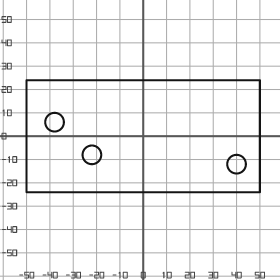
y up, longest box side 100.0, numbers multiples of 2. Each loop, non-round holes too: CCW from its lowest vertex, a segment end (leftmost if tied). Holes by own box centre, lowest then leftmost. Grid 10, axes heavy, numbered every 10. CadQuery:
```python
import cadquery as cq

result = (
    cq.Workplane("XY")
    .moveTo(-50.0, -24.0)
    .lineTo(50.0, -24.0)
    .lineTo(50.0, 24.0)
    .lineTo(-50.0, 24.0)
    .close()
    .moveTo(40.0, -12.0)
    .circle(4.0)
    .moveTo(-22.0, -8.0)
    .circle(4.0)
    .moveTo(-38.0, 6.0)
    .circle(4.0)
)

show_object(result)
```